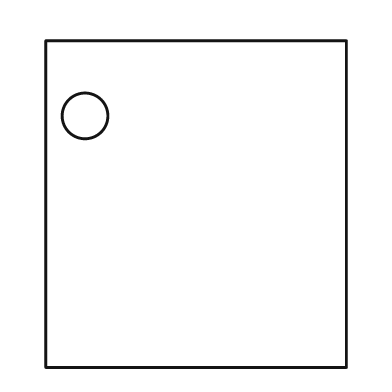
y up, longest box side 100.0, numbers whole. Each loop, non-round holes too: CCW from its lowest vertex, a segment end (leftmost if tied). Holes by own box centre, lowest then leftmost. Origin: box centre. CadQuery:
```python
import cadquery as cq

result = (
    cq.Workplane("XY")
    .moveTo(-46.0, -50.0)
    .lineTo(46.0, -50.0)
    .lineTo(46.0, 50.0)
    .lineTo(-46.0, 50.0)
    .close()
    .moveTo(-34.0, 27.0)
    .circle(7.0)
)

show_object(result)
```